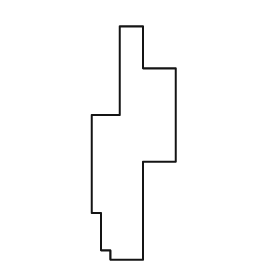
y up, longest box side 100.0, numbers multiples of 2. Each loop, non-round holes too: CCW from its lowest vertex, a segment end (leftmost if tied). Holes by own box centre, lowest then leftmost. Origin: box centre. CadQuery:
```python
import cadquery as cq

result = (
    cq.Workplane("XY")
    .moveTo(-10.0, -50.0)
    .lineTo(4.0, -50.0)
    .lineTo(4.0, -8.0)
    .lineTo(18.0, -8.0)
    .lineTo(18.0, 32.0)
    .lineTo(4.0, 32.0)
    .lineTo(4.0, 50.0)
    .lineTo(-6.0, 50.0)
    .lineTo(-6.0, 12.0)
    .lineTo(-18.0, 12.0)
    .lineTo(-18.0, -30.0)
    .lineTo(-14.0, -30.0)
    .lineTo(-14.0, -46.0)
    .lineTo(-10.0, -46.0)
    .close()
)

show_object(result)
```